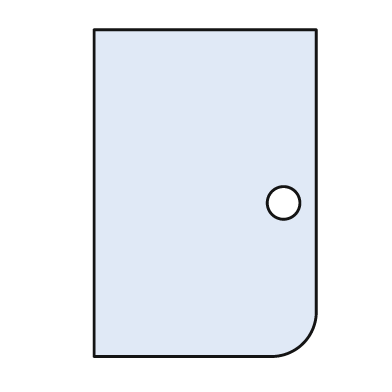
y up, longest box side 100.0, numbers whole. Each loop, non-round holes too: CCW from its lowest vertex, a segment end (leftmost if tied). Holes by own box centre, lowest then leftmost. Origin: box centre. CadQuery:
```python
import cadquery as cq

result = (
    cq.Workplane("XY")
    .moveTo(-34.0, -50.0)
    .lineTo(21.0, -50.0)
    .threePointArc((30.0, -46.0), (34.0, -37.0))
    .lineTo(34.0, 50.0)
    .lineTo(-34.0, 50.0)
    .close()
    .moveTo(24.0, -3.0)
    .circle(5.0)
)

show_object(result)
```